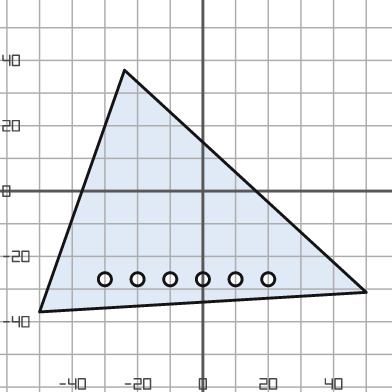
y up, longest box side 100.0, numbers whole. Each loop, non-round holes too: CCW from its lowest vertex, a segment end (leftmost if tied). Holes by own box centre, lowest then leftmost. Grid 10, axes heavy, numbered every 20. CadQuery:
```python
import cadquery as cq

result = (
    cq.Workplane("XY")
    .moveTo(-50.0, -37.0)
    .lineTo(50.0, -31.0)
    .lineTo(-24.0, 37.0)
    .close()
    .moveTo(-30.0, -27.0)
    .circle(2.0)
    .moveTo(-20.0, -27.0)
    .circle(2.0)
    .moveTo(-10.0, -27.0)
    .circle(2.0)
    .moveTo(0.0, -27.0)
    .circle(2.0)
    .moveTo(10.0, -27.0)
    .circle(2.0)
    .moveTo(20.0, -27.0)
    .circle(2.0)
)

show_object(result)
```